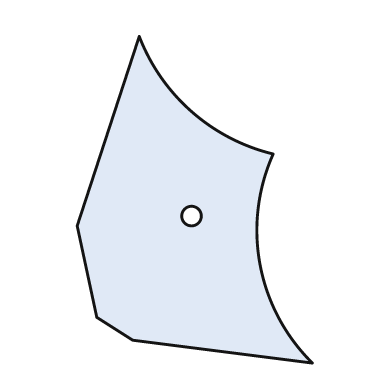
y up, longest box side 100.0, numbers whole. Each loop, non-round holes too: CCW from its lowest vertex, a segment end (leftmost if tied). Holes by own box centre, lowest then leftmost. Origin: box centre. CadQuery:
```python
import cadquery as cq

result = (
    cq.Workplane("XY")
    .moveTo(36.0, -50.0)
    .threePointArc((20.0, -20.0), (24.0, 14.0))
    .threePointArc((-1.0, 27.0), (-17.0, 50.0))
    .lineTo(-36.0, -8.0)
    .lineTo(-30.0, -36.0)
    .lineTo(-19.0, -43.0)
    .close()
    .moveTo(-1.0, -5.0)
    .circle(3.0)
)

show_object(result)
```